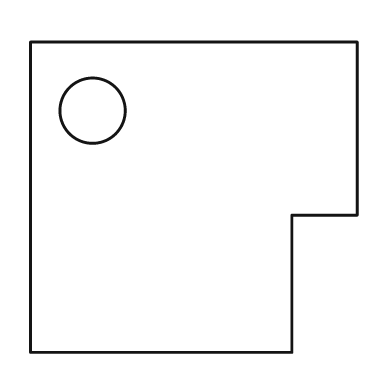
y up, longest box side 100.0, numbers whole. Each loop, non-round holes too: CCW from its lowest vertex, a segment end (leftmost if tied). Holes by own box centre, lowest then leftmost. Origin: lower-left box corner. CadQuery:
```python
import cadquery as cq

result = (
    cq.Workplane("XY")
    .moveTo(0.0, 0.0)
    .lineTo(80.0, 0.0)
    .lineTo(80.0, 42.0)
    .lineTo(100.0, 42.0)
    .lineTo(100.0, 95.0)
    .lineTo(0.0, 95.0)
    .close()
    .moveTo(19.0, 74.0)
    .circle(10.0)
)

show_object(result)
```